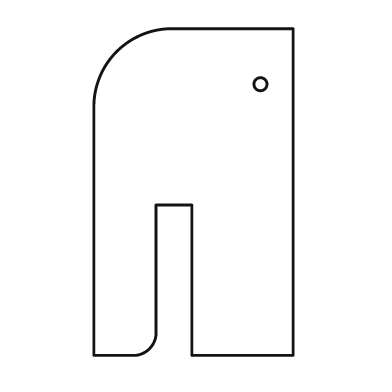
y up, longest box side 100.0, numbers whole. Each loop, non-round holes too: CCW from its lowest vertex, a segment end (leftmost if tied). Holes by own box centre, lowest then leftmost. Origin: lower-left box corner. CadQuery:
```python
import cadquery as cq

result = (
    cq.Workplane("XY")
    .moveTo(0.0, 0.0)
    .lineTo(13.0, 0.0)
    .threePointArc((17.0, 2.0), (19.0, 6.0))
    .lineTo(19.0, 46.0)
    .lineTo(30.0, 46.0)
    .lineTo(30.0, 0.0)
    .lineTo(61.0, 0.0)
    .lineTo(61.0, 100.0)
    .lineTo(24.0, 100.0)
    .threePointArc((7.0, 93.0), (0.0, 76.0))
    .close()
    .moveTo(51.0, 83.0)
    .circle(2.0)
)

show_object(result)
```